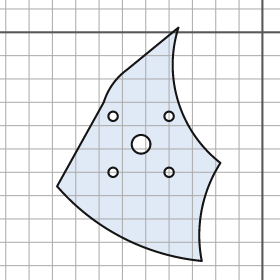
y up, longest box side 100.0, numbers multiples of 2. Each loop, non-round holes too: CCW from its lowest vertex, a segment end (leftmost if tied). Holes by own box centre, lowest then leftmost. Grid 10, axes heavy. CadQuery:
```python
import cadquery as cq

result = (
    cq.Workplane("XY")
    .moveTo(-26.0, -98.0)
    .threePointArc((-26.0, -76.0), (-18.0, -56.0))
    .threePointArc((-36.0, -30.0), (-36.0, 2.0))
    .lineTo(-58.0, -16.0)
    .threePointArc((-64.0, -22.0), (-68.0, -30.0))
    .lineTo(-88.0, -66.0)
    .threePointArc((-60.0, -88.0), (-26.0, -98.0))
    .close()
    .moveTo(-64.0, -60.0)
    .circle(2.0)
    .moveTo(-40.0, -60.0)
    .circle(2.0)
    .moveTo(-52.0, -48.0)
    .circle(4.0)
    .moveTo(-64.0, -36.0)
    .circle(2.0)
    .moveTo(-40.0, -36.0)
    .circle(2.0)
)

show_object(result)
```